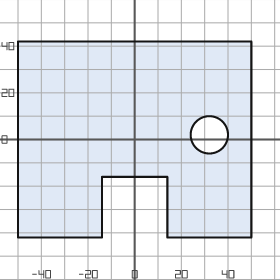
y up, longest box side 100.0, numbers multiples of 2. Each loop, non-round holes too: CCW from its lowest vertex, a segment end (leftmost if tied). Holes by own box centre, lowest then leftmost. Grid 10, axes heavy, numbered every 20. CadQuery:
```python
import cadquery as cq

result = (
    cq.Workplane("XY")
    .moveTo(-50.0, -42.0)
    .lineTo(-14.0, -42.0)
    .lineTo(-14.0, -16.0)
    .lineTo(14.0, -16.0)
    .lineTo(14.0, -42.0)
    .lineTo(50.0, -42.0)
    .lineTo(50.0, 42.0)
    .lineTo(-50.0, 42.0)
    .close()
    .moveTo(32.0, 2.0)
    .circle(8.0)
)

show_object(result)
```